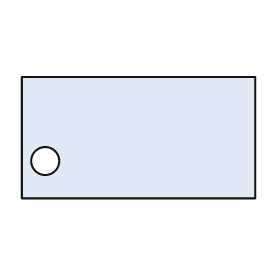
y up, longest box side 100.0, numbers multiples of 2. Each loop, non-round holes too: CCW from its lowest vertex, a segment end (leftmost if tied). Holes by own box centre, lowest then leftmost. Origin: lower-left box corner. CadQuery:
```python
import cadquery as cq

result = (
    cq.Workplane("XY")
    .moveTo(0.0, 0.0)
    .lineTo(100.0, 0.0)
    .lineTo(100.0, 52.0)
    .lineTo(0.0, 52.0)
    .close()
    .moveTo(10.0, 16.0)
    .circle(6.0)
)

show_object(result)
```